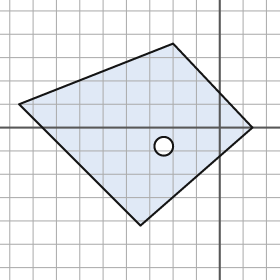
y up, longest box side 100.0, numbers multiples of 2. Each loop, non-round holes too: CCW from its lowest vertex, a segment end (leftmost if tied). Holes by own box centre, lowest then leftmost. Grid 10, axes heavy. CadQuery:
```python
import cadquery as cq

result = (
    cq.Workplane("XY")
    .moveTo(-34.0, -42.0)
    .lineTo(14.0, 0.0)
    .lineTo(-20.0, 36.0)
    .lineTo(-86.0, 10.0)
    .close()
    .moveTo(-24.0, -8.0)
    .circle(4.0)
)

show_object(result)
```